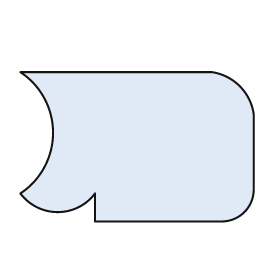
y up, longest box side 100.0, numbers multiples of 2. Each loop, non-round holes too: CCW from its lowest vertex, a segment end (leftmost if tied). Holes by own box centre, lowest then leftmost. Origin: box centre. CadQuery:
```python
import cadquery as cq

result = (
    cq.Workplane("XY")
    .moveTo(-18.0, -32.0)
    .lineTo(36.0, -32.0)
    .threePointArc((46.0, -28.0), (50.0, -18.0))
    .lineTo(50.0, 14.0)
    .threePointArc((44.0, 26.0), (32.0, 32.0))
    .lineTo(-50.0, 32.0)
    .threePointArc((-36.0, 6.0), (-50.0, -20.0))
    .threePointArc((-34.0, -28.0), (-18.0, -20.0))
    .close()
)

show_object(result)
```